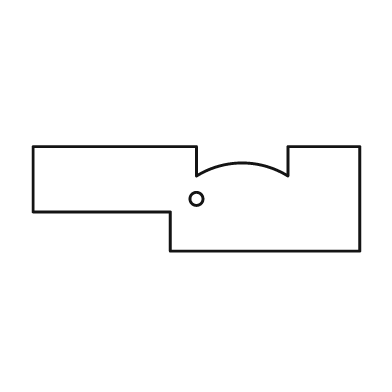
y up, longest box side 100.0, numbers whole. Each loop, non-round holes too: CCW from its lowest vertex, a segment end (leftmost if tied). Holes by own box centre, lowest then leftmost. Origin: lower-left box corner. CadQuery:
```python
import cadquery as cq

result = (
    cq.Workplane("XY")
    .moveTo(42.0, 0.0)
    .lineTo(100.0, 0.0)
    .lineTo(100.0, 32.0)
    .lineTo(78.0, 32.0)
    .lineTo(78.0, 23.0)
    .threePointArc((64.0, 27.0), (50.0, 23.0))
    .lineTo(50.0, 32.0)
    .lineTo(0.0, 32.0)
    .lineTo(0.0, 12.0)
    .lineTo(42.0, 12.0)
    .close()
    .moveTo(50.0, 16.0)
    .circle(2.0)
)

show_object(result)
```